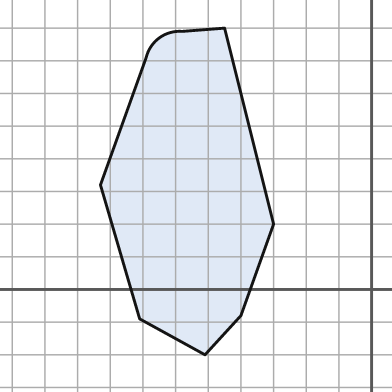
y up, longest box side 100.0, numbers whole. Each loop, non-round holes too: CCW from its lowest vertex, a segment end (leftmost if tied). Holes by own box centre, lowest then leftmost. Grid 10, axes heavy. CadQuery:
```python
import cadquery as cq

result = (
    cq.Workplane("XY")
    .moveTo(-51.0, -20.0)
    .lineTo(-40.0, -8.0)
    .lineTo(-30.0, 20.0)
    .lineTo(-45.0, 80.0)
    .lineTo(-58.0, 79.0)
    .threePointArc((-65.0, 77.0), (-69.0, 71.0))
    .lineTo(-83.0, 32.0)
    .lineTo(-71.0, -9.0)
    .close()
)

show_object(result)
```